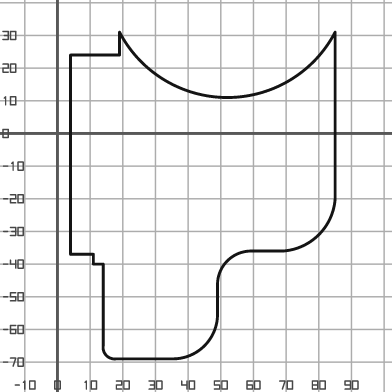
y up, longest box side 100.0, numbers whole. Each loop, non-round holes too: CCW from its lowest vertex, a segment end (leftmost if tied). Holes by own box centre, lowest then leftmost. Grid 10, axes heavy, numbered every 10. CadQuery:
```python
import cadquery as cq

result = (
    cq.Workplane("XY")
    .moveTo(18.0, -69.0)
    .lineTo(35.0, -69.0)
    .threePointArc((45.0, -65.0), (49.0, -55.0))
    .lineTo(49.0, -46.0)
    .threePointArc((52.0, -39.0), (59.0, -36.0))
    .lineTo(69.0, -36.0)
    .threePointArc((80.0, -31.0), (85.0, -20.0))
    .lineTo(85.0, 31.0)
    .threePointArc((52.0, 11.0), (19.0, 31.0))
    .lineTo(19.0, 24.0)
    .lineTo(4.0, 24.0)
    .lineTo(4.0, -37.0)
    .lineTo(11.0, -37.0)
    .lineTo(11.0, -40.0)
    .lineTo(14.0, -40.0)
    .lineTo(14.0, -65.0)
    .threePointArc((15.0, -68.0), (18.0, -69.0))
    .close()
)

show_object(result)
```